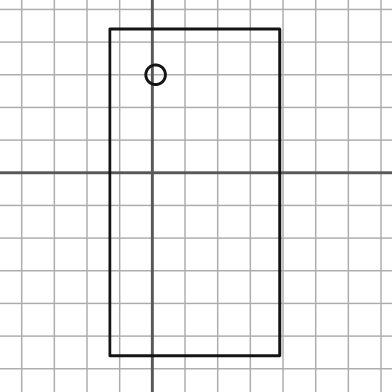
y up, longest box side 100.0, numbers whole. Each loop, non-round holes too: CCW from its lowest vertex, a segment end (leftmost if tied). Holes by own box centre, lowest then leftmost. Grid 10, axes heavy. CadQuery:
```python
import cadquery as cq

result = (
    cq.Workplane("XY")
    .moveTo(-13.0, -56.0)
    .lineTo(39.0, -56.0)
    .lineTo(39.0, 44.0)
    .lineTo(-13.0, 44.0)
    .close()
    .moveTo(1.0, 30.0)
    .circle(3.0)
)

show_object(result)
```